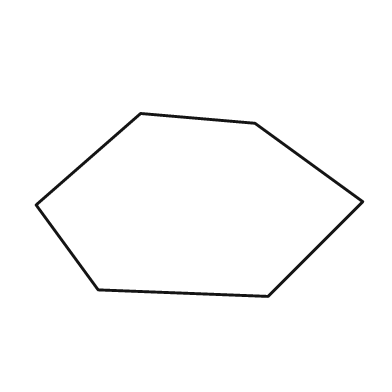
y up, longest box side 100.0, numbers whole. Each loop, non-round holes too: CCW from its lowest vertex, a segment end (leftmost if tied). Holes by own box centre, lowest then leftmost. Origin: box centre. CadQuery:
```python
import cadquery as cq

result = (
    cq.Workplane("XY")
    .moveTo(21.0, -28.0)
    .lineTo(50.0, 1.0)
    .lineTo(17.0, 25.0)
    .lineTo(-18.0, 28.0)
    .lineTo(-50.0, 0.0)
    .lineTo(-31.0, -26.0)
    .close()
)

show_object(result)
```